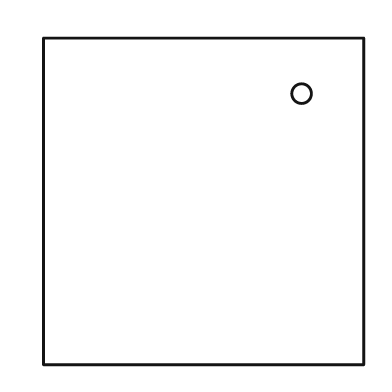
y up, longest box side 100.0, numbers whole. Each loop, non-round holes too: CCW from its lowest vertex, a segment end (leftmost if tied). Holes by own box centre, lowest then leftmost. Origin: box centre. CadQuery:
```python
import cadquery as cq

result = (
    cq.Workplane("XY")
    .moveTo(-49.0, -50.0)
    .lineTo(49.0, -50.0)
    .lineTo(49.0, 50.0)
    .lineTo(-49.0, 50.0)
    .close()
    .moveTo(30.0, 33.0)
    .circle(3.0)
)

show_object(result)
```